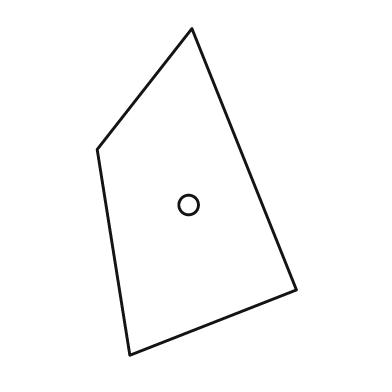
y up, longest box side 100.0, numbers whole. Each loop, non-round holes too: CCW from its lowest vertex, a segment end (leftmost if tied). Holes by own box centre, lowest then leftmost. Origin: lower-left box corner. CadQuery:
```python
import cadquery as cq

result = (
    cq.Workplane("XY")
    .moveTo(10.0, 0.0)
    .lineTo(61.0, 20.0)
    .lineTo(29.0, 100.0)
    .lineTo(0.0, 63.0)
    .close()
    .moveTo(28.0, 46.0)
    .circle(3.0)
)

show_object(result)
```